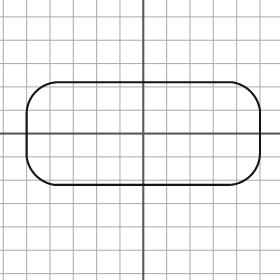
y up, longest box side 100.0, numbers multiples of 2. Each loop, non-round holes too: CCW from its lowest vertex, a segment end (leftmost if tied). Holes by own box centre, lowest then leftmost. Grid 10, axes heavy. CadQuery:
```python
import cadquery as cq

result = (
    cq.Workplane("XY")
    .moveTo(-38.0, -22.0)
    .lineTo(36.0, -22.0)
    .threePointArc((46.0, -18.0), (50.0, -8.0))
    .lineTo(50.0, 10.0)
    .threePointArc((46.0, 18.0), (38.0, 22.0))
    .lineTo(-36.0, 22.0)
    .threePointArc((-46.0, 18.0), (-50.0, 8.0))
    .lineTo(-50.0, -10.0)
    .threePointArc((-46.0, -18.0), (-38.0, -22.0))
    .close()
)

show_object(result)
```